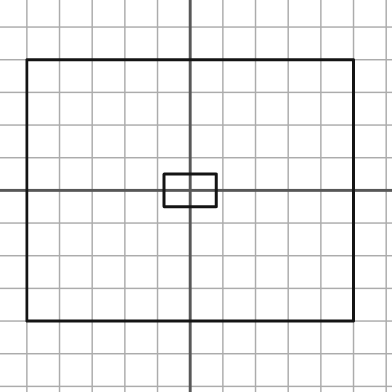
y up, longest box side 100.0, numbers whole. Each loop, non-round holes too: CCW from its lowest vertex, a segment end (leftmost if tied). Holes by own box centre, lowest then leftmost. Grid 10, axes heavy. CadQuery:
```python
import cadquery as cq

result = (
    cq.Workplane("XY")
    .moveTo(-50.0, -40.0)
    .lineTo(50.0, -40.0)
    .lineTo(50.0, 40.0)
    .lineTo(-50.0, 40.0)
    .close()
    .moveTo(-8.0, -5.0)
    .lineTo(8.0, -5.0)
    .lineTo(8.0, 5.0)
    .lineTo(-8.0, 5.0)
    .close()
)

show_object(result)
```